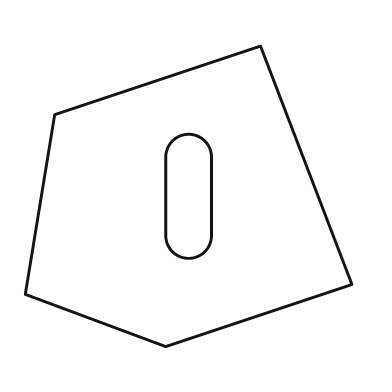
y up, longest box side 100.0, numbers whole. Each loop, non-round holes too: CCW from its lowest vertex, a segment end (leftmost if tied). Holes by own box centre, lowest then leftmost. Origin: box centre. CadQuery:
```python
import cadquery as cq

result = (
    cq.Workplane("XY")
    .moveTo(-7.0, -46.0)
    .lineTo(50.0, -27.0)
    .lineTo(22.0, 46.0)
    .lineTo(-41.0, 25.0)
    .lineTo(-50.0, -30.0)
    .close()
    .moveTo(-7.0, -12.0)
    .threePointArc((0.0, -19.0), (7.0, -12.0))
    .lineTo(7.0, 12.0)
    .threePointArc((0.0, 19.0), (-7.0, 12.0))
    .close()
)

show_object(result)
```